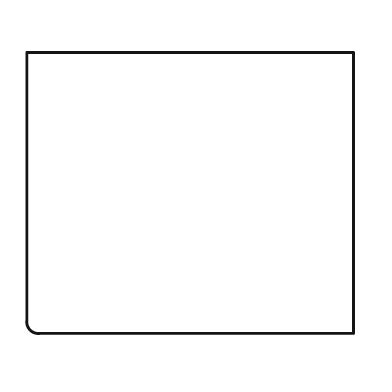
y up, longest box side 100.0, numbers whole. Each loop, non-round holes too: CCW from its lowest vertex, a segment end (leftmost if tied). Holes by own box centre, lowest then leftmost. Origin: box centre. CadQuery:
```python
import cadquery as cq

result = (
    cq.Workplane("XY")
    .moveTo(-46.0, -43.0)
    .lineTo(50.0, -43.0)
    .lineTo(50.0, 43.0)
    .lineTo(-50.0, 43.0)
    .lineTo(-50.0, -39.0)
    .threePointArc((-49.0, -42.0), (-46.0, -43.0))
    .close()
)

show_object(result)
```